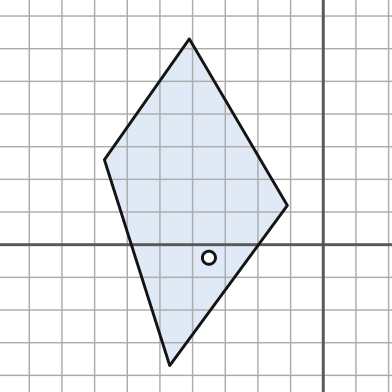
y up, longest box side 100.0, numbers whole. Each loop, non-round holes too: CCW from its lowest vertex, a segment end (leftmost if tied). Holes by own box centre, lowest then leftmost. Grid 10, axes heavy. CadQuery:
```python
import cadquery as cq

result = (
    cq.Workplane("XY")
    .moveTo(-47.0, -37.0)
    .lineTo(-11.0, 12.0)
    .lineTo(-41.0, 63.0)
    .lineTo(-67.0, 26.0)
    .close()
    .moveTo(-35.0, -4.0)
    .circle(2.0)
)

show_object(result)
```